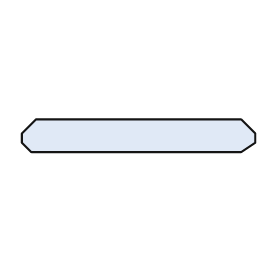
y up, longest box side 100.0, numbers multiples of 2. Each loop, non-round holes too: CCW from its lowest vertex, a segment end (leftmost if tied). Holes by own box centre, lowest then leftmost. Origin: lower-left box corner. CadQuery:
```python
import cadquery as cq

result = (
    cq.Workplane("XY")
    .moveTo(4.0, 0.0)
    .lineTo(94.0, 0.0)
    .lineTo(100.0, 4.0)
    .lineTo(100.0, 8.0)
    .lineTo(94.0, 14.0)
    .lineTo(6.0, 14.0)
    .lineTo(0.0, 8.0)
    .lineTo(0.0, 4.0)
    .close()
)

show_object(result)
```